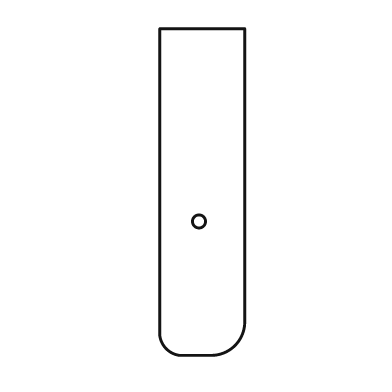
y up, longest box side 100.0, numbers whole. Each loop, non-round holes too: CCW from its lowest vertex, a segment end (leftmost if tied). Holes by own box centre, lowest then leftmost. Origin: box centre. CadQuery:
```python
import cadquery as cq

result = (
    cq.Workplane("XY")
    .moveTo(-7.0, -50.0)
    .lineTo(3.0, -50.0)
    .threePointArc((10.0, -47.0), (13.0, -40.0))
    .lineTo(13.0, 50.0)
    .lineTo(-13.0, 50.0)
    .lineTo(-13.0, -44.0)
    .threePointArc((-11.0, -48.0), (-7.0, -50.0))
    .close()
    .moveTo(-1.0, -9.0)
    .circle(2.0)
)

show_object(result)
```